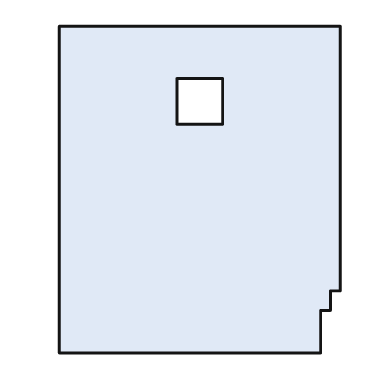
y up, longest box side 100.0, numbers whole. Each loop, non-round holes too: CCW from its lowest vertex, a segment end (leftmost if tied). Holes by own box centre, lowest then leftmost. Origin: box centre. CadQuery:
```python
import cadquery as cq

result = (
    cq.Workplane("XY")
    .moveTo(-43.0, -50.0)
    .lineTo(37.0, -50.0)
    .lineTo(37.0, -37.0)
    .lineTo(40.0, -37.0)
    .lineTo(40.0, -31.0)
    .lineTo(43.0, -31.0)
    .lineTo(43.0, 50.0)
    .lineTo(-43.0, 50.0)
    .close()
    .moveTo(-7.0, 20.0)
    .lineTo(7.0, 20.0)
    .lineTo(7.0, 34.0)
    .lineTo(-7.0, 34.0)
    .close()
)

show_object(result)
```